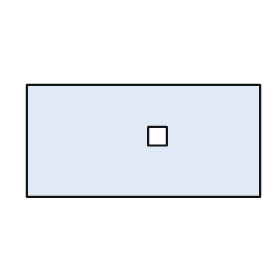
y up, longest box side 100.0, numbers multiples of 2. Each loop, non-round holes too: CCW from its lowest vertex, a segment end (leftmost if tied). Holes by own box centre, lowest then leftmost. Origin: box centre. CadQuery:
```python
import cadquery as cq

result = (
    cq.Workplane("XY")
    .moveTo(-50.0, -24.0)
    .lineTo(50.0, -24.0)
    .lineTo(50.0, 24.0)
    .lineTo(-50.0, 24.0)
    .close()
    .moveTo(2.0, -2.0)
    .lineTo(10.0, -2.0)
    .lineTo(10.0, 6.0)
    .lineTo(2.0, 6.0)
    .close()
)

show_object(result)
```